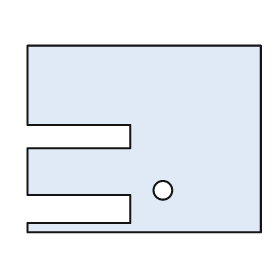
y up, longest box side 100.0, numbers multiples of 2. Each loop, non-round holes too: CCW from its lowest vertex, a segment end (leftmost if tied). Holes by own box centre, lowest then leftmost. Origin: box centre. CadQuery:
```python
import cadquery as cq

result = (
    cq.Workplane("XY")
    .moveTo(-50.0, -40.0)
    .lineTo(50.0, -40.0)
    .lineTo(50.0, 40.0)
    .lineTo(-50.0, 40.0)
    .lineTo(-50.0, 6.0)
    .lineTo(-6.0, 6.0)
    .lineTo(-6.0, -4.0)
    .lineTo(-50.0, -4.0)
    .lineTo(-50.0, -24.0)
    .lineTo(-6.0, -24.0)
    .lineTo(-6.0, -36.0)
    .lineTo(-50.0, -36.0)
    .close()
    .moveTo(8.0, -22.0)
    .circle(4.0)
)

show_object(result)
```